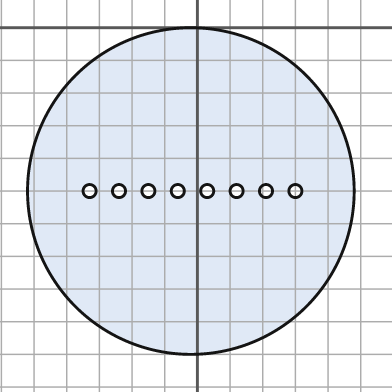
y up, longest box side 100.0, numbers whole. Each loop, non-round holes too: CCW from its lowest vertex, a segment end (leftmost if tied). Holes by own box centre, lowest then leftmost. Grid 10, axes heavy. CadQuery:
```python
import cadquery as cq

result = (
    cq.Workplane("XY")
    .moveTo(-2.0, -50.0)
    .circle(50.0)
    .moveTo(-33.0, -50.0)
    .circle(2.0)
    .moveTo(-24.0, -50.0)
    .circle(2.0)
    .moveTo(-15.0, -50.0)
    .circle(2.0)
    .moveTo(-6.0, -50.0)
    .circle(2.0)
    .moveTo(3.0, -50.0)
    .circle(2.0)
    .moveTo(12.0, -50.0)
    .circle(2.0)
    .moveTo(21.0, -50.0)
    .circle(2.0)
    .moveTo(30.0, -50.0)
    .circle(2.0)
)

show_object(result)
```